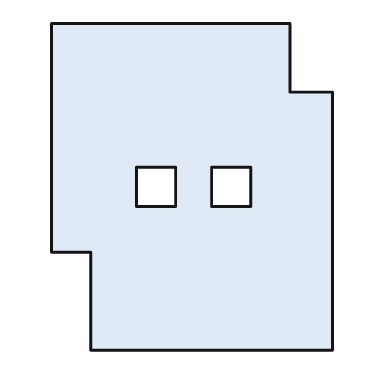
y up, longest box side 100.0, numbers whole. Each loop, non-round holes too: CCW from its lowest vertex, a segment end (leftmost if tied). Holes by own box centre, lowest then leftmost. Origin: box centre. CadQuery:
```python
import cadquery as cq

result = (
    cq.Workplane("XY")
    .moveTo(-31.0, -50.0)
    .lineTo(43.0, -50.0)
    .lineTo(43.0, 29.0)
    .lineTo(30.0, 29.0)
    .lineTo(30.0, 50.0)
    .lineTo(-43.0, 50.0)
    .lineTo(-43.0, -20.0)
    .lineTo(-31.0, -20.0)
    .close()
    .moveTo(-17.0, -6.0)
    .lineTo(-5.0, -6.0)
    .lineTo(-5.0, 6.0)
    .lineTo(-17.0, 6.0)
    .close()
    .moveTo(6.0, -6.0)
    .lineTo(18.0, -6.0)
    .lineTo(18.0, 6.0)
    .lineTo(6.0, 6.0)
    .close()
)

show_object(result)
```